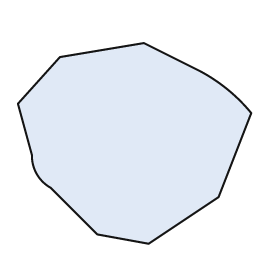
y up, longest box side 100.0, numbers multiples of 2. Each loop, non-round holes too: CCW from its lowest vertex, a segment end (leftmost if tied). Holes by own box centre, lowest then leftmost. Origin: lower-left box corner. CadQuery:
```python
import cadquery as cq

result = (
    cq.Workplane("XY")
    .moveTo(56.0, 0.0)
    .lineTo(86.0, 20.0)
    .lineTo(100.0, 56.0)
    .threePointArc((90.0, 66.0), (78.0, 74.0))
    .lineTo(54.0, 86.0)
    .lineTo(18.0, 80.0)
    .lineTo(0.0, 60.0)
    .lineTo(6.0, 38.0)
    .threePointArc((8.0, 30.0), (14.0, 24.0))
    .lineTo(34.0, 4.0)
    .close()
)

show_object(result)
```